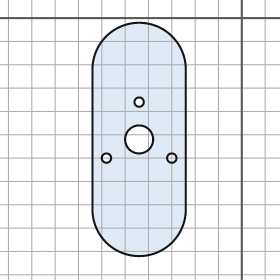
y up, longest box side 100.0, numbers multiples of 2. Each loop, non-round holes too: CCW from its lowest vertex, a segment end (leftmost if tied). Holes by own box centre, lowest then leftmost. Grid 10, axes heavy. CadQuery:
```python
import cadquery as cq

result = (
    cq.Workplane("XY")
    .moveTo(-64.0, -82.0)
    .threePointArc((-44.0, -102.0), (-24.0, -82.0))
    .lineTo(-24.0, -22.0)
    .threePointArc((-44.0, -2.0), (-64.0, -22.0))
    .close()
    .moveTo(-58.0, -60.0)
    .circle(2.0)
    .moveTo(-30.0, -60.0)
    .circle(2.0)
    .moveTo(-44.0, -52.0)
    .circle(6.0)
    .moveTo(-44.0, -36.0)
    .circle(2.0)
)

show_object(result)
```